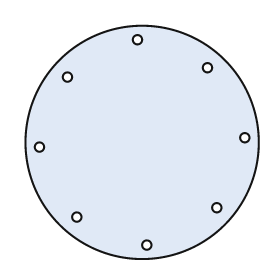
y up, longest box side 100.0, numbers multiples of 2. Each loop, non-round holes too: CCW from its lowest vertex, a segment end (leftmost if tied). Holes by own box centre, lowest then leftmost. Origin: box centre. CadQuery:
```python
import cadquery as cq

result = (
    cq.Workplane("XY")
    .moveTo(0.0, 0.0)
    .circle(50.0)
    .moveTo(2.0, -44.0)
    .circle(2.0)
    .moveTo(-28.0, -32.0)
    .circle(2.0)
    .moveTo(32.0, -28.0)
    .circle(2.0)
    .moveTo(-44.0, -2.0)
    .circle(2.0)
    .moveTo(44.0, 2.0)
    .circle(2.0)
    .moveTo(-32.0, 28.0)
    .circle(2.0)
    .moveTo(28.0, 32.0)
    .circle(2.0)
    .moveTo(-2.0, 44.0)
    .circle(2.0)
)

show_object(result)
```